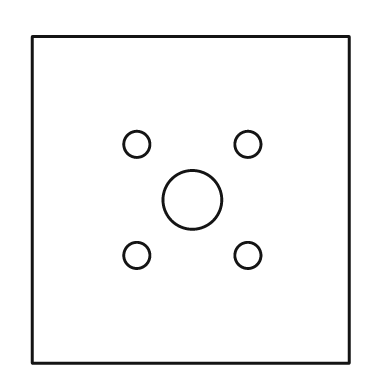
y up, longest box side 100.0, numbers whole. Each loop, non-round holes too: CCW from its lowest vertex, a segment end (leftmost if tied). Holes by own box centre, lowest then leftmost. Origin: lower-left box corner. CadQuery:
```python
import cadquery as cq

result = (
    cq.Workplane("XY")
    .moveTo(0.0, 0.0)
    .lineTo(97.0, 0.0)
    .lineTo(97.0, 100.0)
    .lineTo(0.0, 100.0)
    .close()
    .moveTo(32.0, 33.0)
    .circle(4.0)
    .moveTo(66.0, 33.0)
    .circle(4.0)
    .moveTo(49.0, 50.0)
    .circle(9.0)
    .moveTo(32.0, 67.0)
    .circle(4.0)
    .moveTo(66.0, 67.0)
    .circle(4.0)
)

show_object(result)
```